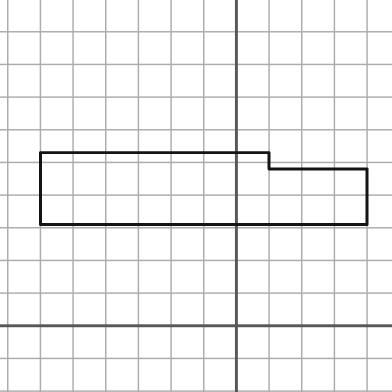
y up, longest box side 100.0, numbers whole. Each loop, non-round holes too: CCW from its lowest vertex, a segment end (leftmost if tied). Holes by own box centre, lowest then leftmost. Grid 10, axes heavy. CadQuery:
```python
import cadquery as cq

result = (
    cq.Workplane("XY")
    .moveTo(-60.0, 31.0)
    .lineTo(40.0, 31.0)
    .lineTo(40.0, 48.0)
    .lineTo(10.0, 48.0)
    .lineTo(10.0, 53.0)
    .lineTo(-60.0, 53.0)
    .close()
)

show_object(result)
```